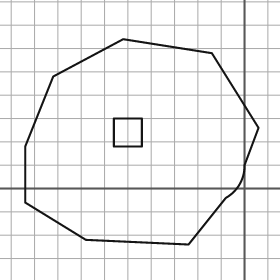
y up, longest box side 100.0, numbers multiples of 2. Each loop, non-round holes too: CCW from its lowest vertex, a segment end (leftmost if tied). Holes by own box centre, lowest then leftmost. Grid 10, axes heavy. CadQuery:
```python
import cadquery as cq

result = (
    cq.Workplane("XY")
    .moveTo(-24.0, -24.0)
    .lineTo(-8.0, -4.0)
    .threePointArc((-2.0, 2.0), (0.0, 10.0))
    .lineTo(6.0, 26.0)
    .lineTo(-14.0, 58.0)
    .lineTo(-52.0, 64.0)
    .lineTo(-82.0, 48.0)
    .lineTo(-94.0, 18.0)
    .lineTo(-94.0, -6.0)
    .lineTo(-68.0, -22.0)
    .close()
    .moveTo(-56.0, 18.0)
    .lineTo(-44.0, 18.0)
    .lineTo(-44.0, 30.0)
    .lineTo(-56.0, 30.0)
    .close()
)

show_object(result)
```